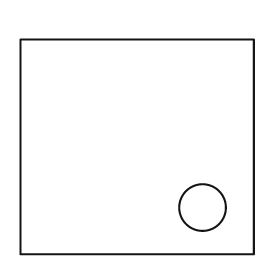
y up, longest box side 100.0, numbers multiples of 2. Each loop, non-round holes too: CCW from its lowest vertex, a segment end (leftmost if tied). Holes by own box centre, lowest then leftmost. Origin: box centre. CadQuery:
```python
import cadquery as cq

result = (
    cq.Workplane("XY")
    .moveTo(-50.0, -46.0)
    .lineTo(50.0, -46.0)
    .lineTo(50.0, 46.0)
    .lineTo(-50.0, 46.0)
    .close()
    .moveTo(28.0, -26.0)
    .circle(10.0)
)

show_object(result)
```